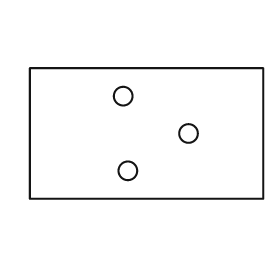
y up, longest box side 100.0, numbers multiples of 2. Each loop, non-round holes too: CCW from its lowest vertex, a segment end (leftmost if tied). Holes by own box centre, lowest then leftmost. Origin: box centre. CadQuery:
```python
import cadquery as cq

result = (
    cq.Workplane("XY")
    .moveTo(-50.0, -28.0)
    .lineTo(50.0, -28.0)
    .lineTo(50.0, 28.0)
    .lineTo(-50.0, 28.0)
    .close()
    .moveTo(-8.0, -16.0)
    .circle(4.0)
    .moveTo(18.0, 0.0)
    .circle(4.0)
    .moveTo(-10.0, 16.0)
    .circle(4.0)
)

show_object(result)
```